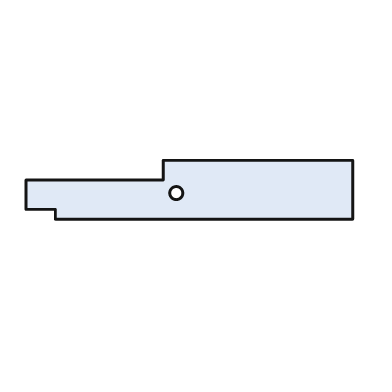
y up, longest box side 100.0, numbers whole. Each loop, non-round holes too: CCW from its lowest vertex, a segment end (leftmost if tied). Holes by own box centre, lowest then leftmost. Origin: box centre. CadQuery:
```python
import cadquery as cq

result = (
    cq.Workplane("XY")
    .moveTo(-41.0, -9.0)
    .lineTo(50.0, -9.0)
    .lineTo(50.0, 9.0)
    .lineTo(-8.0, 9.0)
    .lineTo(-8.0, 3.0)
    .lineTo(-50.0, 3.0)
    .lineTo(-50.0, -6.0)
    .lineTo(-41.0, -6.0)
    .close()
    .moveTo(-4.0, -1.0)
    .circle(2.0)
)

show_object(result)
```